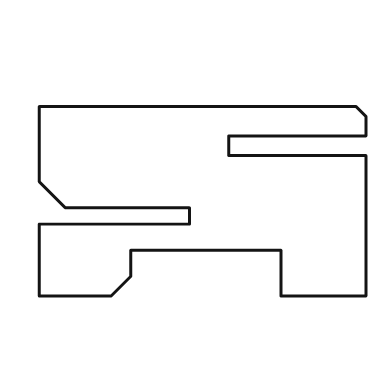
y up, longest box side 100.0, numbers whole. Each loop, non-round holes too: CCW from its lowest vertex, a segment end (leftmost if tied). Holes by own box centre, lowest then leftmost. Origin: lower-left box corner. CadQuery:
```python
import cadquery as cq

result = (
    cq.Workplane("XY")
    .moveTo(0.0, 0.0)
    .lineTo(22.0, 0.0)
    .lineTo(28.0, 6.0)
    .lineTo(28.0, 14.0)
    .lineTo(74.0, 14.0)
    .lineTo(74.0, 0.0)
    .lineTo(100.0, 0.0)
    .lineTo(100.0, 43.0)
    .lineTo(58.0, 43.0)
    .lineTo(58.0, 49.0)
    .lineTo(100.0, 49.0)
    .lineTo(100.0, 55.0)
    .lineTo(97.0, 58.0)
    .lineTo(0.0, 58.0)
    .lineTo(0.0, 35.0)
    .lineTo(8.0, 27.0)
    .lineTo(46.0, 27.0)
    .lineTo(46.0, 22.0)
    .lineTo(0.0, 22.0)
    .close()
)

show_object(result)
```